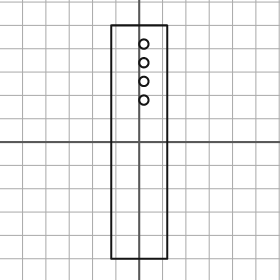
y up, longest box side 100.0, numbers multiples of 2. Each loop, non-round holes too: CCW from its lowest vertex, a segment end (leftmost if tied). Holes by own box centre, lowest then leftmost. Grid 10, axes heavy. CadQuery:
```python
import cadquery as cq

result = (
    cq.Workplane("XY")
    .moveTo(-12.0, -50.0)
    .lineTo(12.0, -50.0)
    .lineTo(12.0, 50.0)
    .lineTo(-12.0, 50.0)
    .close()
    .moveTo(2.0, 18.0)
    .circle(2.0)
    .moveTo(2.0, 26.0)
    .circle(2.0)
    .moveTo(2.0, 34.0)
    .circle(2.0)
    .moveTo(2.0, 42.0)
    .circle(2.0)
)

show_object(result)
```